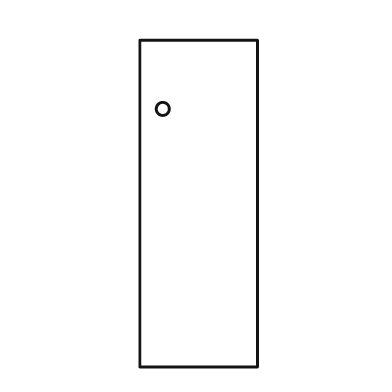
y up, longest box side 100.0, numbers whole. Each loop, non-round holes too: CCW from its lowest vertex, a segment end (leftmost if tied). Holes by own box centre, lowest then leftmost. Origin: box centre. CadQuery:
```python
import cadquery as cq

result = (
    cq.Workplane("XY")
    .moveTo(-18.0, -50.0)
    .lineTo(18.0, -50.0)
    .lineTo(18.0, 50.0)
    .lineTo(-18.0, 50.0)
    .close()
    .moveTo(-11.0, 29.0)
    .circle(2.0)
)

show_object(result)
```